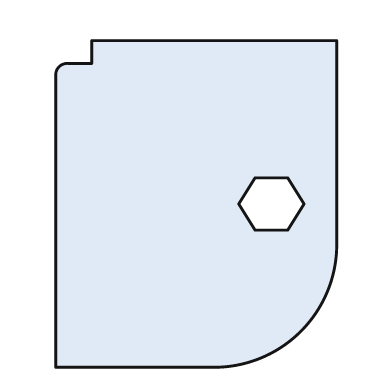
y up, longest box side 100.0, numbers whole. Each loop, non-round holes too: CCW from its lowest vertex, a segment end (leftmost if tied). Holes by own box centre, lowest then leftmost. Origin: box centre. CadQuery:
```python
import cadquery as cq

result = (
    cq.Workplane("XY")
    .moveTo(-43.0, -50.0)
    .lineTo(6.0, -50.0)
    .threePointArc((32.0, -39.0), (43.0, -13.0))
    .lineTo(43.0, 50.0)
    .lineTo(-32.0, 50.0)
    .lineTo(-32.0, 43.0)
    .lineTo(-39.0, 43.0)
    .threePointArc((-42.0, 42.0), (-43.0, 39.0))
    .close()
    .moveTo(18.0, -8.0)
    .lineTo(28.0, -8.0)
    .lineTo(33.0, 0.0)
    .lineTo(28.0, 8.0)
    .lineTo(18.0, 8.0)
    .lineTo(13.0, 0.0)
    .close()
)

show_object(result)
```